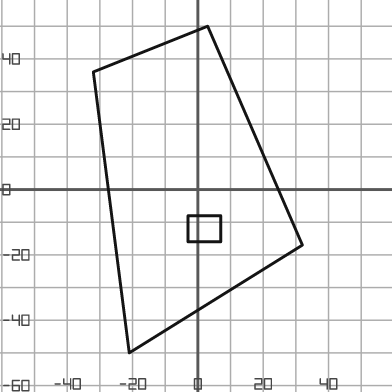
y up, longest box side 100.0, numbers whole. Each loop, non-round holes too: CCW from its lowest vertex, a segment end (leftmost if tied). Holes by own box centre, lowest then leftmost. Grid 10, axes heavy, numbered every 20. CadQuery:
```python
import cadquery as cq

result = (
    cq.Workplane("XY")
    .moveTo(-21.0, -50.0)
    .lineTo(32.0, -17.0)
    .lineTo(3.0, 50.0)
    .lineTo(-32.0, 36.0)
    .close()
    .moveTo(-3.0, -16.0)
    .lineTo(7.0, -16.0)
    .lineTo(7.0, -8.0)
    .lineTo(-3.0, -8.0)
    .close()
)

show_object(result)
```